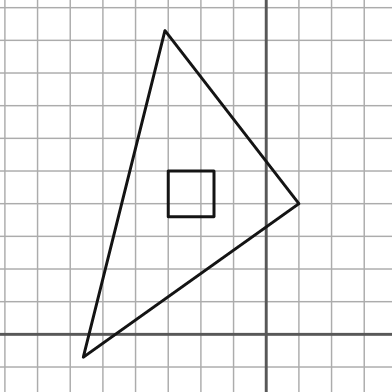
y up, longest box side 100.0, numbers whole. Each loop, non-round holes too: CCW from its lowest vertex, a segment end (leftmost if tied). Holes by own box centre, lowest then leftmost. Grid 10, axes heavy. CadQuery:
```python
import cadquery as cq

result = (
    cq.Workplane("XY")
    .moveTo(-56.0, -7.0)
    .lineTo(10.0, 40.0)
    .lineTo(-31.0, 93.0)
    .close()
    .moveTo(-30.0, 36.0)
    .lineTo(-16.0, 36.0)
    .lineTo(-16.0, 50.0)
    .lineTo(-30.0, 50.0)
    .close()
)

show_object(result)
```